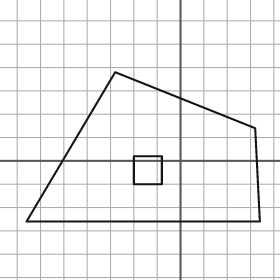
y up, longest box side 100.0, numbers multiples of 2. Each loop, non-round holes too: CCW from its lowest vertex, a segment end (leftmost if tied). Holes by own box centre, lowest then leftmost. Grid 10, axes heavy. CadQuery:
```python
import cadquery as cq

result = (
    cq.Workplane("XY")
    .moveTo(-66.0, -26.0)
    .lineTo(34.0, -26.0)
    .lineTo(32.0, 14.0)
    .lineTo(-28.0, 38.0)
    .close()
    .moveTo(-20.0, -10.0)
    .lineTo(-8.0, -10.0)
    .lineTo(-8.0, 2.0)
    .lineTo(-20.0, 2.0)
    .close()
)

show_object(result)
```